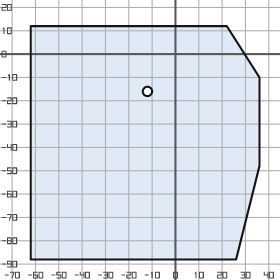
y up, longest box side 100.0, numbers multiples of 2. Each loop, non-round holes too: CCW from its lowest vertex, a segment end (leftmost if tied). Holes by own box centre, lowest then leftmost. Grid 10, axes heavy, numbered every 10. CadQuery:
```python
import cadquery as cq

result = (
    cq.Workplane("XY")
    .moveTo(-62.0, -88.0)
    .lineTo(26.0, -88.0)
    .lineTo(36.0, -48.0)
    .lineTo(36.0, -10.0)
    .lineTo(22.0, 12.0)
    .lineTo(-62.0, 12.0)
    .close()
    .moveTo(-12.0, -16.0)
    .circle(2.0)
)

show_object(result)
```